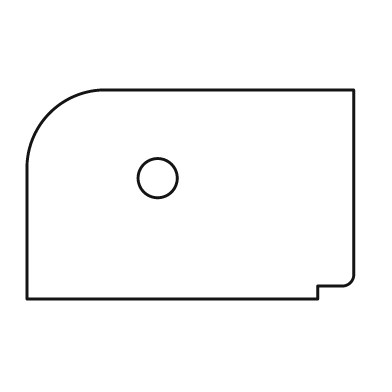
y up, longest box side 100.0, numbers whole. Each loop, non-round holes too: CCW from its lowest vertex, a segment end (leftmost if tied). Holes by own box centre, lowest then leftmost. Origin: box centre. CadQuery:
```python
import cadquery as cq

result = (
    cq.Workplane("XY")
    .moveTo(-50.0, -32.0)
    .lineTo(39.0, -32.0)
    .lineTo(39.0, -28.0)
    .lineTo(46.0, -28.0)
    .threePointArc((49.0, -27.0), (50.0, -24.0))
    .lineTo(50.0, 32.0)
    .lineTo(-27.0, 32.0)
    .threePointArc((-43.0, 25.0), (-50.0, 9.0))
    .close()
    .moveTo(-10.0, 5.0)
    .circle(6.0)
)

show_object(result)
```